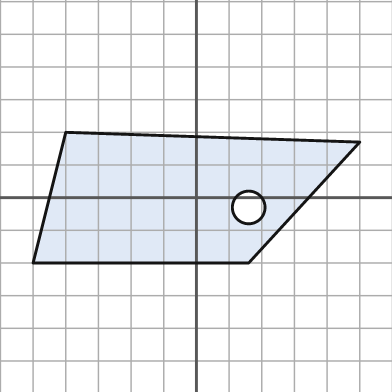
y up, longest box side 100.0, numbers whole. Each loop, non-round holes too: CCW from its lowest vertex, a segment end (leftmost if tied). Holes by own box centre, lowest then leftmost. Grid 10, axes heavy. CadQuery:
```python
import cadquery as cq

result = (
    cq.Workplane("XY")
    .moveTo(-50.0, -20.0)
    .lineTo(16.0, -20.0)
    .lineTo(50.0, 17.0)
    .lineTo(-40.0, 20.0)
    .close()
    .moveTo(16.0, -3.0)
    .circle(5.0)
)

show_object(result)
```